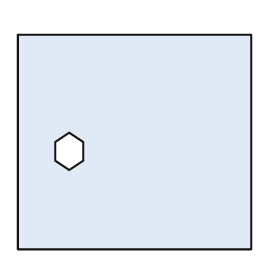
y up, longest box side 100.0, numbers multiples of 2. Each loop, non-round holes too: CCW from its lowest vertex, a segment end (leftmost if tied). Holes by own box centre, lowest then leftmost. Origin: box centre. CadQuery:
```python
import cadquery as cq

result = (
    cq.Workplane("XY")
    .moveTo(-50.0, -46.0)
    .lineTo(50.0, -46.0)
    .lineTo(50.0, 46.0)
    .lineTo(-50.0, 46.0)
    .close()
    .moveTo(-28.0, -12.0)
    .lineTo(-22.0, -8.0)
    .lineTo(-22.0, 0.0)
    .lineTo(-28.0, 4.0)
    .lineTo(-34.0, 0.0)
    .lineTo(-34.0, -8.0)
    .close()
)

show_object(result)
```